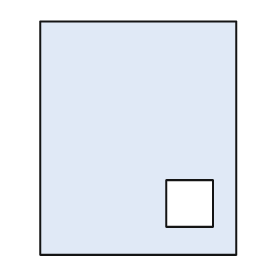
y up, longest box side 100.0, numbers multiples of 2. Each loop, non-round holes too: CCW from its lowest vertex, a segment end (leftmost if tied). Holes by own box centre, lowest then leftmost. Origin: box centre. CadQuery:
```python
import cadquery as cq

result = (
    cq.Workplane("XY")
    .moveTo(-42.0, -50.0)
    .lineTo(42.0, -50.0)
    .lineTo(42.0, 50.0)
    .lineTo(-42.0, 50.0)
    .close()
    .moveTo(12.0, -38.0)
    .lineTo(32.0, -38.0)
    .lineTo(32.0, -18.0)
    .lineTo(12.0, -18.0)
    .close()
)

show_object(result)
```